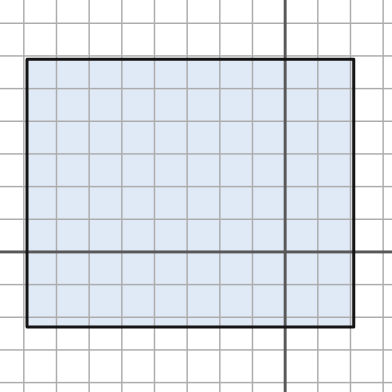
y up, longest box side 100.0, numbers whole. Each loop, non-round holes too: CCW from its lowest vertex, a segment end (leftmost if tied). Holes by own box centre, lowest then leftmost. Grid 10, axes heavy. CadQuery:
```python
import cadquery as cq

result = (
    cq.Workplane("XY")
    .moveTo(-79.0, -23.0)
    .lineTo(21.0, -23.0)
    .lineTo(21.0, 59.0)
    .lineTo(-79.0, 59.0)
    .close()
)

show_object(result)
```